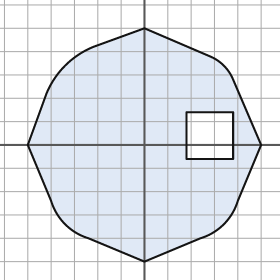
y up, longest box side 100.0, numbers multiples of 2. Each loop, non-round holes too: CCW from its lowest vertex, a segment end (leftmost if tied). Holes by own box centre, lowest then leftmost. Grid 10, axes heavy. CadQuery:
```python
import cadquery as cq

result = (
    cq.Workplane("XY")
    .moveTo(0.0, -50.0)
    .lineTo(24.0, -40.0)
    .threePointArc((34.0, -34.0), (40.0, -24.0))
    .lineTo(50.0, 0.0)
    .lineTo(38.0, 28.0)
    .threePointArc((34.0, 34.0), (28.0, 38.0))
    .lineTo(0.0, 50.0)
    .lineTo(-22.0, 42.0)
    .threePointArc((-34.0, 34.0), (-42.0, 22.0))
    .lineTo(-50.0, 0.0)
    .lineTo(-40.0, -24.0)
    .threePointArc((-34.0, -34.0), (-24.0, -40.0))
    .close()
    .moveTo(18.0, -6.0)
    .lineTo(38.0, -6.0)
    .lineTo(38.0, 14.0)
    .lineTo(18.0, 14.0)
    .close()
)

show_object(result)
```